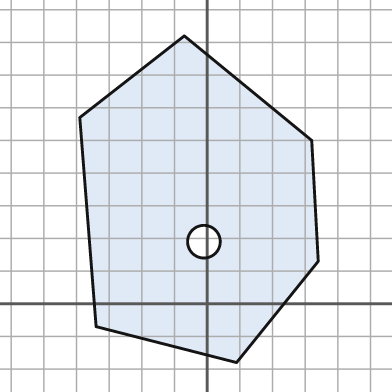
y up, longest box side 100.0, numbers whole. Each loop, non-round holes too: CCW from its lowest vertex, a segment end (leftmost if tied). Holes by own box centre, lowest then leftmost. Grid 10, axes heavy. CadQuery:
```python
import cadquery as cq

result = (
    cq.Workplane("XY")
    .moveTo(9.0, -18.0)
    .lineTo(34.0, 13.0)
    .lineTo(32.0, 50.0)
    .lineTo(-7.0, 82.0)
    .lineTo(-39.0, 57.0)
    .lineTo(-34.0, -7.0)
    .close()
    .moveTo(-1.0, 19.0)
    .circle(5.0)
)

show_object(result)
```